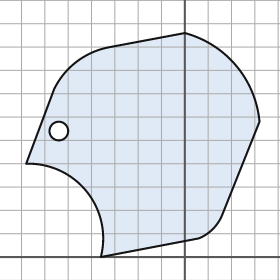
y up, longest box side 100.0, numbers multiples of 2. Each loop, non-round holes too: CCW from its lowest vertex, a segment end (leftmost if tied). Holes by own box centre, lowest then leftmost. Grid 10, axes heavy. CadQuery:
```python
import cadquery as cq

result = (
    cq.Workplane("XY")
    .moveTo(-36.0, 0.0)
    .lineTo(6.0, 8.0)
    .threePointArc((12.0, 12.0), (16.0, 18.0))
    .lineTo(32.0, 58.0)
    .threePointArc((22.0, 82.0), (0.0, 96.0))
    .lineTo(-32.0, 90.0)
    .threePointArc((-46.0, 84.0), (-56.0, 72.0))
    .lineTo(-68.0, 40.0)
    .threePointArc((-42.0, 28.0), (-36.0, 0.0))
    .close()
    .moveTo(-54.0, 54.0)
    .circle(4.0)
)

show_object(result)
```